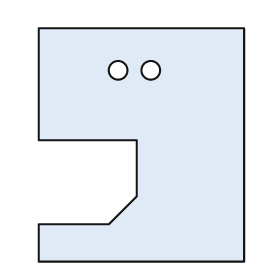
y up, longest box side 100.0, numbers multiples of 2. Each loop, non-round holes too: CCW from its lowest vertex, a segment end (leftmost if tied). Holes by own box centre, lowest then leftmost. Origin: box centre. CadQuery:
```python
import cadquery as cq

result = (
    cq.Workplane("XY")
    .moveTo(-44.0, -50.0)
    .lineTo(44.0, -50.0)
    .lineTo(44.0, 50.0)
    .lineTo(-44.0, 50.0)
    .lineTo(-44.0, 2.0)
    .lineTo(-2.0, 2.0)
    .lineTo(-2.0, -22.0)
    .lineTo(-14.0, -34.0)
    .lineTo(-44.0, -34.0)
    .close()
    .moveTo(-10.0, 32.0)
    .circle(4.0)
    .moveTo(4.0, 32.0)
    .circle(4.0)
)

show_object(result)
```